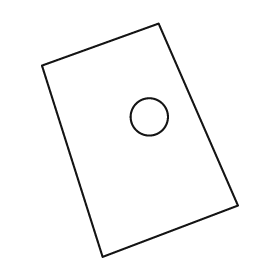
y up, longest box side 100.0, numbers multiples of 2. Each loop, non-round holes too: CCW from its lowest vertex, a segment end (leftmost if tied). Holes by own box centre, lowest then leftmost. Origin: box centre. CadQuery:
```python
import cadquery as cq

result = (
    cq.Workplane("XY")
    .moveTo(-16.0, -50.0)
    .lineTo(42.0, -28.0)
    .lineTo(8.0, 50.0)
    .lineTo(-42.0, 32.0)
    .close()
    .moveTo(4.0, 10.0)
    .circle(8.0)
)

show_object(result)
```